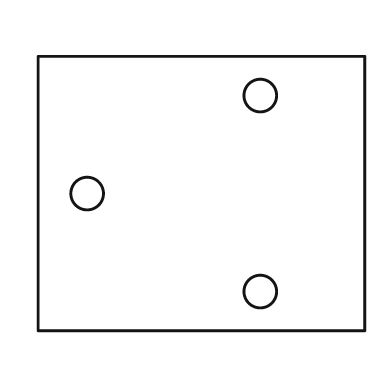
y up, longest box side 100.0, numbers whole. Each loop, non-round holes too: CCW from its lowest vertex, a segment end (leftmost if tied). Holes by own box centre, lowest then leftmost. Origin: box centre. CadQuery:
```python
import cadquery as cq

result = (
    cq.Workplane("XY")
    .moveTo(-50.0, -42.0)
    .lineTo(50.0, -42.0)
    .lineTo(50.0, 42.0)
    .lineTo(-50.0, 42.0)
    .close()
    .moveTo(18.0, -30.0)
    .circle(5.0)
    .moveTo(-35.0, 0.0)
    .circle(5.0)
    .moveTo(18.0, 30.0)
    .circle(5.0)
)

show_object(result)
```